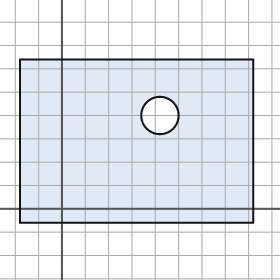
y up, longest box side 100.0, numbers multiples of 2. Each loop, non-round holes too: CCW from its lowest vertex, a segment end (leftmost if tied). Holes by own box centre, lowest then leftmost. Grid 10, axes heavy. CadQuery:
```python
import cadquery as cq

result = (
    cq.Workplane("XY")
    .moveTo(-18.0, -6.0)
    .lineTo(82.0, -6.0)
    .lineTo(82.0, 64.0)
    .lineTo(-18.0, 64.0)
    .close()
    .moveTo(42.0, 40.0)
    .circle(8.0)
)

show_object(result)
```